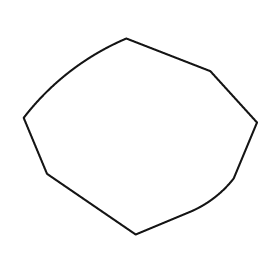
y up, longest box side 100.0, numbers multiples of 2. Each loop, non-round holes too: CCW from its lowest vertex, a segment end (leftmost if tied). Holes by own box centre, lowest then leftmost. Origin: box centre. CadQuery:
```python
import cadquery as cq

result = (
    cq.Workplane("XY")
    .moveTo(-2.0, -42.0)
    .lineTo(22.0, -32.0)
    .threePointArc((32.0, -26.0), (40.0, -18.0))
    .lineTo(50.0, 6.0)
    .lineTo(30.0, 28.0)
    .lineTo(-6.0, 42.0)
    .threePointArc((-30.0, 28.0), (-50.0, 8.0))
    .lineTo(-40.0, -16.0)
    .close()
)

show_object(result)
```